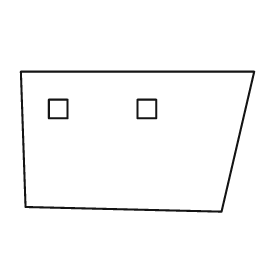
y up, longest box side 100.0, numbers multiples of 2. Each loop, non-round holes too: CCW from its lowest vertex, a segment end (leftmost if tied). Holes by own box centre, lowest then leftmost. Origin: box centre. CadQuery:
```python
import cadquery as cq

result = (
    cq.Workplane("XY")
    .moveTo(36.0, -30.0)
    .lineTo(50.0, 30.0)
    .lineTo(-50.0, 30.0)
    .lineTo(-48.0, -28.0)
    .close()
    .moveTo(-38.0, 10.0)
    .lineTo(-30.0, 10.0)
    .lineTo(-30.0, 18.0)
    .lineTo(-38.0, 18.0)
    .close()
    .moveTo(0.0, 10.0)
    .lineTo(8.0, 10.0)
    .lineTo(8.0, 18.0)
    .lineTo(0.0, 18.0)
    .close()
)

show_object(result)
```